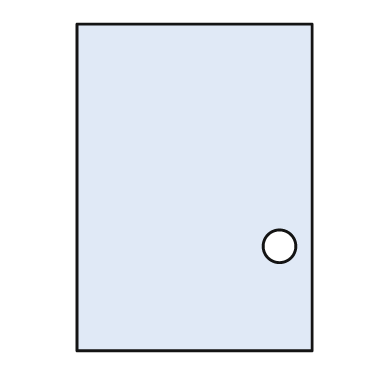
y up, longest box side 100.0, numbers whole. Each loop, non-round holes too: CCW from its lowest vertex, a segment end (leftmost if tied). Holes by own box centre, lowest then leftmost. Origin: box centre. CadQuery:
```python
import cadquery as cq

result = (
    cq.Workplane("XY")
    .moveTo(-36.0, -50.0)
    .lineTo(36.0, -50.0)
    .lineTo(36.0, 50.0)
    .lineTo(-36.0, 50.0)
    .close()
    .moveTo(26.0, -18.0)
    .circle(5.0)
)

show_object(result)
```